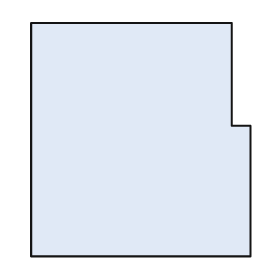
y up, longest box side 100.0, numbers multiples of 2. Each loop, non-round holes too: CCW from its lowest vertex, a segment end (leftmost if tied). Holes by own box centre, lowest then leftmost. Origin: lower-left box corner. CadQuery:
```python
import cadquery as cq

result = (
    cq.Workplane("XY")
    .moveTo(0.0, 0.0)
    .lineTo(94.0, 0.0)
    .lineTo(94.0, 56.0)
    .lineTo(86.0, 56.0)
    .lineTo(86.0, 100.0)
    .lineTo(0.0, 100.0)
    .close()
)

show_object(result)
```